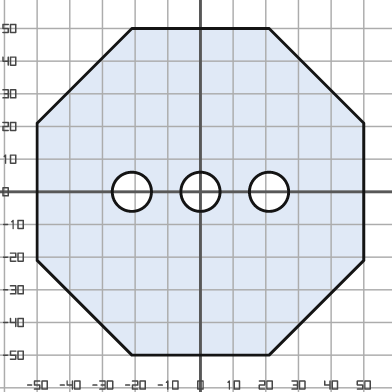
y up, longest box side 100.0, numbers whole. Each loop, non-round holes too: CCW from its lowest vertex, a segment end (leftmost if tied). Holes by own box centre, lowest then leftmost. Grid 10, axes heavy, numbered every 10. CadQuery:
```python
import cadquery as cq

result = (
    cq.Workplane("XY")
    .moveTo(-21.0, -50.0)
    .lineTo(21.0, -50.0)
    .lineTo(50.0, -21.0)
    .lineTo(50.0, 21.0)
    .lineTo(21.0, 50.0)
    .lineTo(-21.0, 50.0)
    .lineTo(-50.0, 21.0)
    .lineTo(-50.0, -21.0)
    .close()
    .moveTo(-21.0, 0.0)
    .circle(6.0)
    .moveTo(0.0, 0.0)
    .circle(6.0)
    .moveTo(21.0, 0.0)
    .circle(6.0)
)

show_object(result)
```